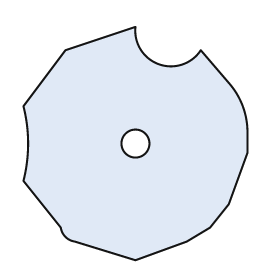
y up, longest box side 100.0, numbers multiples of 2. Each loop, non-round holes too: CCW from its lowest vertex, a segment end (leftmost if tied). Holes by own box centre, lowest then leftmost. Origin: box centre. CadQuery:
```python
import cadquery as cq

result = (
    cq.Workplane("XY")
    .moveTo(0.0, -50.0)
    .lineTo(22.0, -42.0)
    .lineTo(32.0, -36.0)
    .lineTo(40.0, -26.0)
    .lineTo(48.0, -4.0)
    .lineTo(48.0, 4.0)
    .threePointArc((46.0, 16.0), (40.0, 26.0))
    .lineTo(28.0, 40.0)
    .threePointArc((10.0, 34.0), (0.0, 50.0))
    .lineTo(-30.0, 40.0)
    .lineTo(-48.0, 16.0)
    .threePointArc((-46.0, 0.0), (-48.0, -16.0))
    .lineTo(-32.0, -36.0)
    .threePointArc((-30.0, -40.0), (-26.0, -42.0))
    .close()
    .moveTo(0.0, 0.0)
    .circle(6.0)
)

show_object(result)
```